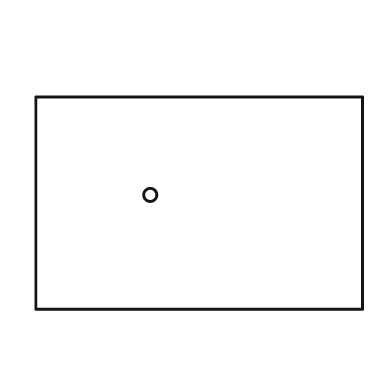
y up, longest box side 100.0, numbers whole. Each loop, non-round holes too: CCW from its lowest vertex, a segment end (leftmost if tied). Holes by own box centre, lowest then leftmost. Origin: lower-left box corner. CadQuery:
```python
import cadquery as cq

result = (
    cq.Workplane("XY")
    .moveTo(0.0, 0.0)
    .lineTo(100.0, 0.0)
    .lineTo(100.0, 65.0)
    .lineTo(0.0, 65.0)
    .close()
    .moveTo(35.0, 35.0)
    .circle(2.0)
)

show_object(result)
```